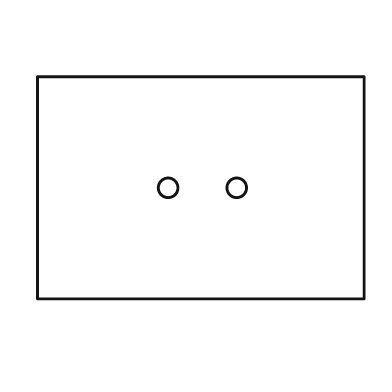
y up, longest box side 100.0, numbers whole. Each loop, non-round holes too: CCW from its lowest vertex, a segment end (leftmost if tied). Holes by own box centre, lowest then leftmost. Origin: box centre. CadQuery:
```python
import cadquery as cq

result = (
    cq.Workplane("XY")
    .moveTo(-50.0, -34.0)
    .lineTo(50.0, -34.0)
    .lineTo(50.0, 34.0)
    .lineTo(-50.0, 34.0)
    .close()
    .moveTo(-10.0, 0.0)
    .circle(3.0)
    .moveTo(11.0, 0.0)
    .circle(3.0)
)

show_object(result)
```